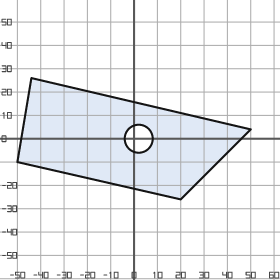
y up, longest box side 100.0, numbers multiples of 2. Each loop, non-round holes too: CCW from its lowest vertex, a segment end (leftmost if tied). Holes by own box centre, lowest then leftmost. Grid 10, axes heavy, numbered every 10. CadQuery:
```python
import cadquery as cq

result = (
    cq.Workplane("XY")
    .moveTo(20.0, -26.0)
    .lineTo(50.0, 4.0)
    .lineTo(-44.0, 26.0)
    .lineTo(-50.0, -10.0)
    .close()
    .moveTo(2.0, 0.0)
    .circle(6.0)
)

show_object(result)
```